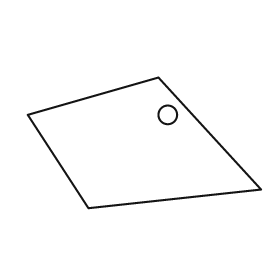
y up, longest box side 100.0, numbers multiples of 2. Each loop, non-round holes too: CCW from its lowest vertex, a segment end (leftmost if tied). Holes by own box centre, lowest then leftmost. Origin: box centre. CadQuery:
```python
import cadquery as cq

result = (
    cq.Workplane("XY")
    .moveTo(-24.0, -28.0)
    .lineTo(50.0, -20.0)
    .lineTo(6.0, 28.0)
    .lineTo(-50.0, 12.0)
    .close()
    .moveTo(10.0, 12.0)
    .circle(4.0)
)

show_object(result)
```